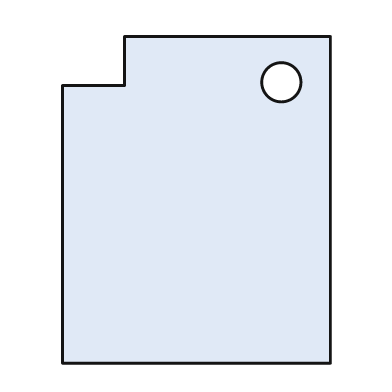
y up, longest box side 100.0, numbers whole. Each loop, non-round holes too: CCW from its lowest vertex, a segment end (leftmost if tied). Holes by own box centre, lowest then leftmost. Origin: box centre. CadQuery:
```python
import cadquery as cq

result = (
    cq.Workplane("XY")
    .moveTo(-41.0, -50.0)
    .lineTo(41.0, -50.0)
    .lineTo(41.0, 50.0)
    .lineTo(-22.0, 50.0)
    .lineTo(-22.0, 35.0)
    .lineTo(-41.0, 35.0)
    .close()
    .moveTo(26.0, 36.0)
    .circle(6.0)
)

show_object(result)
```